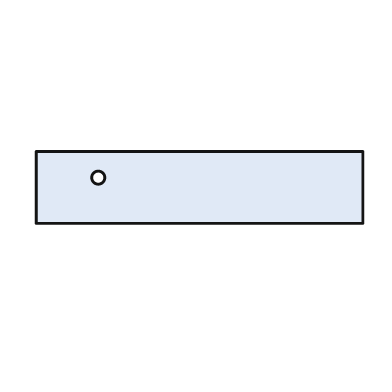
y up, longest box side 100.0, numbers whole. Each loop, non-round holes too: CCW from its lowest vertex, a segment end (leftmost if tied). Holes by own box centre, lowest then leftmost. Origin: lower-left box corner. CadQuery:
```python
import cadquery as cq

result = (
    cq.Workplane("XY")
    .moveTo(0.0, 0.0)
    .lineTo(100.0, 0.0)
    .lineTo(100.0, 22.0)
    .lineTo(0.0, 22.0)
    .close()
    .moveTo(19.0, 14.0)
    .circle(2.0)
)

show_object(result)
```